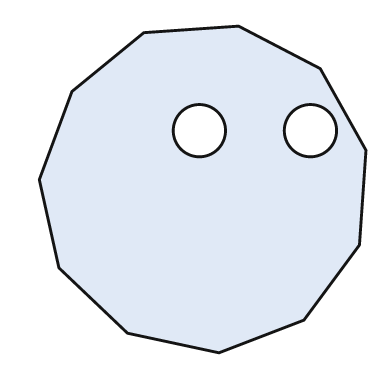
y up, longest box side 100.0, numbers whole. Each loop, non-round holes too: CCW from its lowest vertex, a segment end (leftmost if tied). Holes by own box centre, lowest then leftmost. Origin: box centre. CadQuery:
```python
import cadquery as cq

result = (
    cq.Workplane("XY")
    .moveTo(5.0, -50.0)
    .lineTo(31.0, -40.0)
    .lineTo(48.0, -17.0)
    .lineTo(50.0, 12.0)
    .lineTo(36.0, 37.0)
    .lineTo(11.0, 50.0)
    .lineTo(-18.0, 48.0)
    .lineTo(-40.0, 30.0)
    .lineTo(-50.0, 3.0)
    .lineTo(-44.0, -24.0)
    .lineTo(-23.0, -44.0)
    .close()
    .moveTo(-1.0, 18.0)
    .circle(8.0)
    .moveTo(33.0, 18.0)
    .circle(8.0)
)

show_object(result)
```